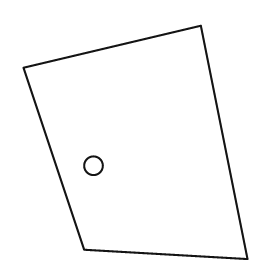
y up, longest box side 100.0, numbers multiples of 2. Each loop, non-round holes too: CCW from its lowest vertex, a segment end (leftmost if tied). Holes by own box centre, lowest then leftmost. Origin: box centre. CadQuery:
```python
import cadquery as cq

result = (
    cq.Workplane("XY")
    .moveTo(48.0, -50.0)
    .lineTo(28.0, 50.0)
    .lineTo(-48.0, 32.0)
    .lineTo(-22.0, -46.0)
    .close()
    .moveTo(-18.0, -10.0)
    .circle(4.0)
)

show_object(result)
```